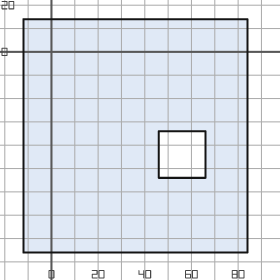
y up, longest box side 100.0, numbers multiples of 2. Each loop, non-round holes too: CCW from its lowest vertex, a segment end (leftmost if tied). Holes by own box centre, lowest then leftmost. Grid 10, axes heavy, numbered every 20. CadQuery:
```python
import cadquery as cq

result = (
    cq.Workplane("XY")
    .moveTo(-12.0, -86.0)
    .lineTo(84.0, -86.0)
    .lineTo(84.0, 14.0)
    .lineTo(-12.0, 14.0)
    .close()
    .moveTo(46.0, -54.0)
    .lineTo(66.0, -54.0)
    .lineTo(66.0, -34.0)
    .lineTo(46.0, -34.0)
    .close()
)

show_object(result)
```